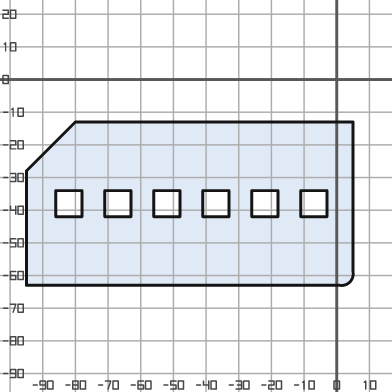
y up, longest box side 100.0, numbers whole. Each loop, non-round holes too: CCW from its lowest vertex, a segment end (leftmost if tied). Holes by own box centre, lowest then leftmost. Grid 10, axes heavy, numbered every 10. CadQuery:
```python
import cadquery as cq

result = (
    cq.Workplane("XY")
    .moveTo(-95.0, -63.0)
    .lineTo(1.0, -63.0)
    .threePointArc((4.0, -62.0), (5.0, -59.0))
    .lineTo(5.0, -13.0)
    .lineTo(-80.0, -13.0)
    .lineTo(-95.0, -28.0)
    .close()
    .moveTo(-86.0, -42.0)
    .lineTo(-78.0, -42.0)
    .lineTo(-78.0, -34.0)
    .lineTo(-86.0, -34.0)
    .close()
    .moveTo(-71.0, -42.0)
    .lineTo(-63.0, -42.0)
    .lineTo(-63.0, -34.0)
    .lineTo(-71.0, -34.0)
    .close()
    .moveTo(-56.0, -42.0)
    .lineTo(-48.0, -42.0)
    .lineTo(-48.0, -34.0)
    .lineTo(-56.0, -34.0)
    .close()
    .moveTo(-41.0, -42.0)
    .lineTo(-33.0, -42.0)
    .lineTo(-33.0, -34.0)
    .lineTo(-41.0, -34.0)
    .close()
    .moveTo(-26.0, -42.0)
    .lineTo(-18.0, -42.0)
    .lineTo(-18.0, -34.0)
    .lineTo(-26.0, -34.0)
    .close()
    .moveTo(-11.0, -42.0)
    .lineTo(-3.0, -42.0)
    .lineTo(-3.0, -34.0)
    .lineTo(-11.0, -34.0)
    .close()
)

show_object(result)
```